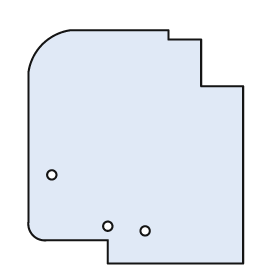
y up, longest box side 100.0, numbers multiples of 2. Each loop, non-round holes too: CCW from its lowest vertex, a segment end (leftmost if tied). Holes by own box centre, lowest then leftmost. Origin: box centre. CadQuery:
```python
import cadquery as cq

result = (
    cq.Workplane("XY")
    .moveTo(-12.0, -50.0)
    .lineTo(46.0, -50.0)
    .lineTo(46.0, 26.0)
    .lineTo(28.0, 26.0)
    .lineTo(28.0, 46.0)
    .lineTo(14.0, 46.0)
    .lineTo(14.0, 50.0)
    .lineTo(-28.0, 50.0)
    .threePointArc((-40.0, 44.0), (-46.0, 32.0))
    .lineTo(-46.0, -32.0)
    .threePointArc((-44.0, -38.0), (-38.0, -40.0))
    .lineTo(-12.0, -40.0)
    .close()
    .moveTo(4.0, -36.0)
    .circle(2.0)
    .moveTo(-12.0, -34.0)
    .circle(2.0)
    .moveTo(-36.0, -12.0)
    .circle(2.0)
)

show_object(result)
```